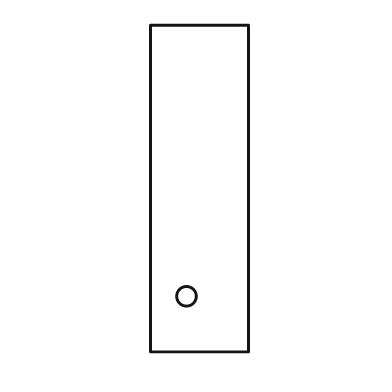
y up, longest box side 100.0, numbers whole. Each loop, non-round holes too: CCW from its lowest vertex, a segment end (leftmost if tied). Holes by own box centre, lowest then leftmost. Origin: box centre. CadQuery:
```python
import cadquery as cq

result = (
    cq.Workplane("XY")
    .moveTo(-15.0, -50.0)
    .lineTo(15.0, -50.0)
    .lineTo(15.0, 50.0)
    .lineTo(-15.0, 50.0)
    .close()
    .moveTo(-4.0, -33.0)
    .circle(3.0)
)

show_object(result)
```